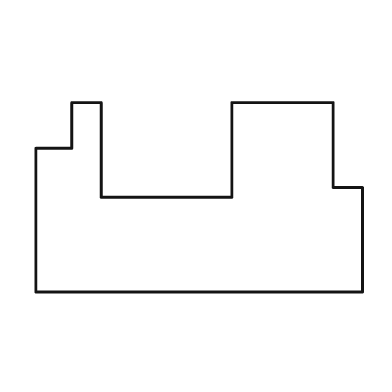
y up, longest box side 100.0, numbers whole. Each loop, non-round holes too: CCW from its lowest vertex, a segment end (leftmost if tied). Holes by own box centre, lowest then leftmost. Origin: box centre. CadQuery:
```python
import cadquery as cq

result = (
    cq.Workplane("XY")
    .moveTo(-50.0, -29.0)
    .lineTo(50.0, -29.0)
    .lineTo(50.0, 3.0)
    .lineTo(41.0, 3.0)
    .lineTo(41.0, 29.0)
    .lineTo(10.0, 29.0)
    .lineTo(10.0, 0.0)
    .lineTo(-30.0, 0.0)
    .lineTo(-30.0, 29.0)
    .lineTo(-39.0, 29.0)
    .lineTo(-39.0, 15.0)
    .lineTo(-50.0, 15.0)
    .close()
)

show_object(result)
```